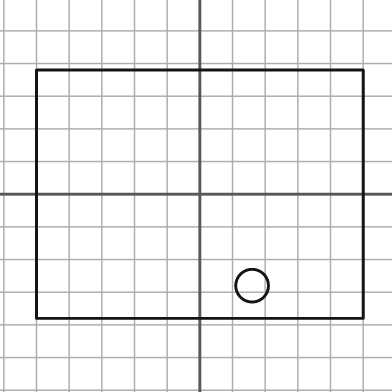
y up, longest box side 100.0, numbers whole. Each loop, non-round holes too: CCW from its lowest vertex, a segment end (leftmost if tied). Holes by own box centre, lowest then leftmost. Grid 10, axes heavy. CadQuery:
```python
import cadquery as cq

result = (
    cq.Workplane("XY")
    .moveTo(-50.0, -38.0)
    .lineTo(50.0, -38.0)
    .lineTo(50.0, 38.0)
    .lineTo(-50.0, 38.0)
    .close()
    .moveTo(16.0, -28.0)
    .circle(5.0)
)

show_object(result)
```